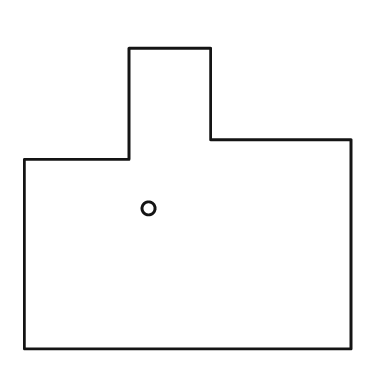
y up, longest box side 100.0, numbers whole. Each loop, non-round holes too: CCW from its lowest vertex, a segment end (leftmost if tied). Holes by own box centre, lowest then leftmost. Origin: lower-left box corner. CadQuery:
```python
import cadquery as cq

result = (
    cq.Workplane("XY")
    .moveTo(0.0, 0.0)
    .lineTo(100.0, 0.0)
    .lineTo(100.0, 64.0)
    .lineTo(57.0, 64.0)
    .lineTo(57.0, 92.0)
    .lineTo(32.0, 92.0)
    .lineTo(32.0, 58.0)
    .lineTo(0.0, 58.0)
    .close()
    .moveTo(38.0, 43.0)
    .circle(2.0)
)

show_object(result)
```